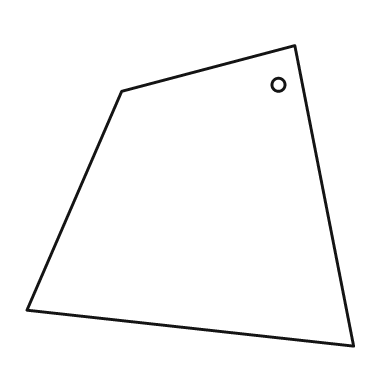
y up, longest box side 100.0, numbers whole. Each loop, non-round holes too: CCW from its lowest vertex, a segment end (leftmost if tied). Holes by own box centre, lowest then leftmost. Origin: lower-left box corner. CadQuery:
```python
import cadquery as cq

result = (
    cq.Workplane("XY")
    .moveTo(100.0, 0.0)
    .lineTo(82.0, 92.0)
    .lineTo(29.0, 78.0)
    .lineTo(0.0, 11.0)
    .close()
    .moveTo(77.0, 80.0)
    .circle(2.0)
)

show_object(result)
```